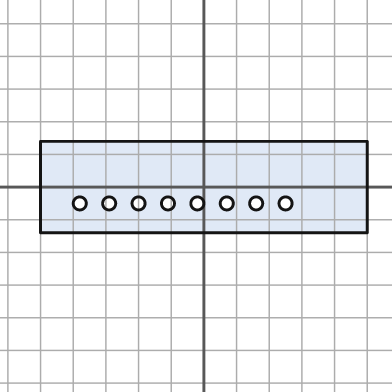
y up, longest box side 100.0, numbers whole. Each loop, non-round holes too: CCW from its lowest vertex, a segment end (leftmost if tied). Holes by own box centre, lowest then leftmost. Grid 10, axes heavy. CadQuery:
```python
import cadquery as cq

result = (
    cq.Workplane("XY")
    .moveTo(-50.0, -14.0)
    .lineTo(50.0, -14.0)
    .lineTo(50.0, 14.0)
    .lineTo(-50.0, 14.0)
    .close()
    .moveTo(-38.0, -5.0)
    .circle(2.0)
    .moveTo(-29.0, -5.0)
    .circle(2.0)
    .moveTo(-20.0, -5.0)
    .circle(2.0)
    .moveTo(-11.0, -5.0)
    .circle(2.0)
    .moveTo(-2.0, -5.0)
    .circle(2.0)
    .moveTo(7.0, -5.0)
    .circle(2.0)
    .moveTo(16.0, -5.0)
    .circle(2.0)
    .moveTo(25.0, -5.0)
    .circle(2.0)
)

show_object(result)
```